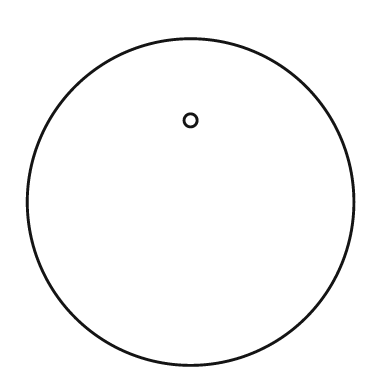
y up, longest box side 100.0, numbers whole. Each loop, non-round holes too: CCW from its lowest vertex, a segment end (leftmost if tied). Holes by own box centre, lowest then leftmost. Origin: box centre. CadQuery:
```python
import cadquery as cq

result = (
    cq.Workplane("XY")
    .moveTo(0.0, 0.0)
    .circle(50.0)
    .moveTo(0.0, 25.0)
    .circle(2.0)
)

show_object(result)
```